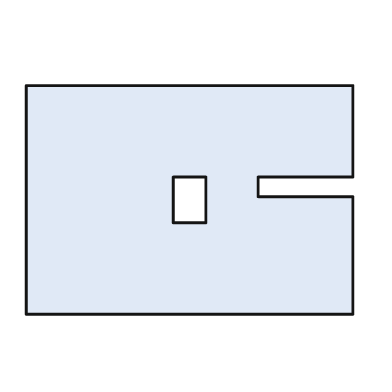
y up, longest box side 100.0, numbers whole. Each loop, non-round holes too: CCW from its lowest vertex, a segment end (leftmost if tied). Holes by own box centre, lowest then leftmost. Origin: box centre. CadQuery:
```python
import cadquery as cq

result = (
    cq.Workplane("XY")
    .moveTo(-50.0, -35.0)
    .lineTo(50.0, -35.0)
    .lineTo(50.0, 1.0)
    .lineTo(21.0, 1.0)
    .lineTo(21.0, 7.0)
    .lineTo(50.0, 7.0)
    .lineTo(50.0, 35.0)
    .lineTo(-50.0, 35.0)
    .close()
    .moveTo(-5.0, -7.0)
    .lineTo(5.0, -7.0)
    .lineTo(5.0, 7.0)
    .lineTo(-5.0, 7.0)
    .close()
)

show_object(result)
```